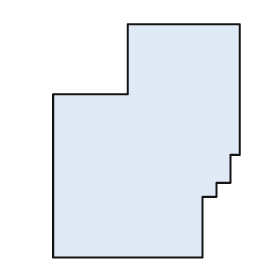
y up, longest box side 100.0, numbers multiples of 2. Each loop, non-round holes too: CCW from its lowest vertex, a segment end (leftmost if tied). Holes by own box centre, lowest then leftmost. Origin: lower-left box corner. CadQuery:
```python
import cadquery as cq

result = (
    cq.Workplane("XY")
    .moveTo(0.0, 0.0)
    .lineTo(64.0, 0.0)
    .lineTo(64.0, 26.0)
    .lineTo(70.0, 26.0)
    .lineTo(70.0, 32.0)
    .lineTo(76.0, 32.0)
    .lineTo(76.0, 44.0)
    .lineTo(80.0, 44.0)
    .lineTo(80.0, 100.0)
    .lineTo(32.0, 100.0)
    .lineTo(32.0, 70.0)
    .lineTo(0.0, 70.0)
    .close()
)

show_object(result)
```